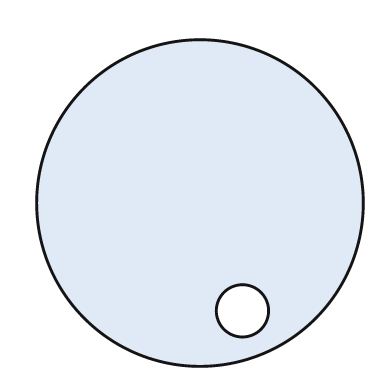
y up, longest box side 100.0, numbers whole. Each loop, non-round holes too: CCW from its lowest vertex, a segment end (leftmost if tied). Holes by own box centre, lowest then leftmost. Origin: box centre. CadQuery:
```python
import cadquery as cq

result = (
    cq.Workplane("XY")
    .moveTo(0.0, 0.0)
    .circle(50.0)
    .moveTo(13.0, -33.0)
    .circle(8.0)
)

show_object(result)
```